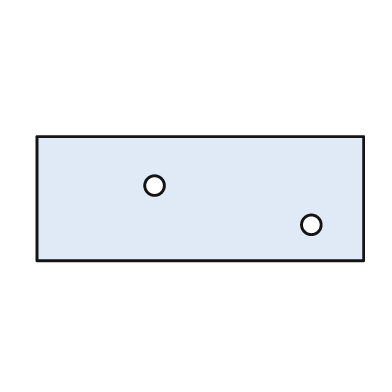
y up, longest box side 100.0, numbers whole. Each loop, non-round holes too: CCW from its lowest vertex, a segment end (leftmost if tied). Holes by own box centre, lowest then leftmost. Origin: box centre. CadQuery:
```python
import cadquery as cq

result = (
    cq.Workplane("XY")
    .moveTo(-50.0, -19.0)
    .lineTo(50.0, -19.0)
    .lineTo(50.0, 19.0)
    .lineTo(-50.0, 19.0)
    .close()
    .moveTo(34.0, -8.0)
    .circle(3.0)
    .moveTo(-14.0, 4.0)
    .circle(3.0)
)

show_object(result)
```